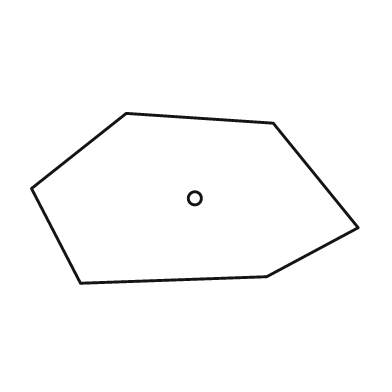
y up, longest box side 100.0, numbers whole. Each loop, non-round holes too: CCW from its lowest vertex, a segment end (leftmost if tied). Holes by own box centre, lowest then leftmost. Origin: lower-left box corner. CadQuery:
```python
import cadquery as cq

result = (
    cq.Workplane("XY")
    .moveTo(15.0, 0.0)
    .lineTo(72.0, 2.0)
    .lineTo(100.0, 17.0)
    .lineTo(74.0, 49.0)
    .lineTo(29.0, 52.0)
    .lineTo(0.0, 29.0)
    .close()
    .moveTo(50.0, 26.0)
    .circle(2.0)
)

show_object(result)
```